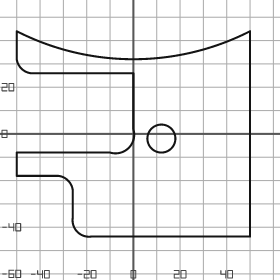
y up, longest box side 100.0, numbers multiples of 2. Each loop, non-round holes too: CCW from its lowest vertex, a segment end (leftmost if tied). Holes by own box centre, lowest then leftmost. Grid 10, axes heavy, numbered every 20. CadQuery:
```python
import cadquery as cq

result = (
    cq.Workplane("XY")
    .moveTo(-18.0, -44.0)
    .lineTo(50.0, -44.0)
    .lineTo(50.0, 44.0)
    .threePointArc((0.0, 32.0), (-50.0, 44.0))
    .lineTo(-50.0, 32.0)
    .threePointArc((-48.0, 28.0), (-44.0, 26.0))
    .lineTo(0.0, 26.0)
    .lineTo(0.0, 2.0)
    .threePointArc((-2.0, -6.0), (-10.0, -8.0))
    .lineTo(-50.0, -8.0)
    .lineTo(-50.0, -18.0)
    .lineTo(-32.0, -18.0)
    .threePointArc((-28.0, -20.0), (-26.0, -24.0))
    .lineTo(-26.0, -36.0)
    .threePointArc((-24.0, -42.0), (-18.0, -44.0))
    .close()
    .moveTo(12.0, -2.0)
    .circle(6.0)
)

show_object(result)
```